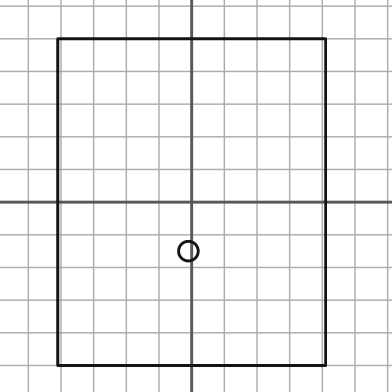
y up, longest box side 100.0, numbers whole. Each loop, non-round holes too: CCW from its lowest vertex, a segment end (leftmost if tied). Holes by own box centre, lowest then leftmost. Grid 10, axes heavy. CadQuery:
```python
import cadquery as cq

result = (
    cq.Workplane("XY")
    .moveTo(-41.0, -50.0)
    .lineTo(41.0, -50.0)
    .lineTo(41.0, 50.0)
    .lineTo(-41.0, 50.0)
    .close()
    .moveTo(-1.0, -15.0)
    .circle(3.0)
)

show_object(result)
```